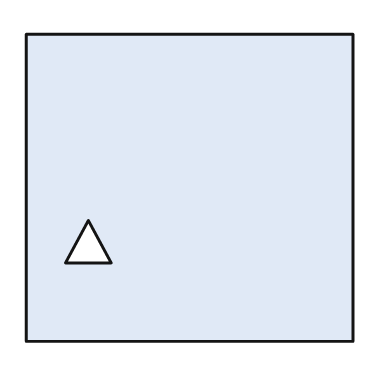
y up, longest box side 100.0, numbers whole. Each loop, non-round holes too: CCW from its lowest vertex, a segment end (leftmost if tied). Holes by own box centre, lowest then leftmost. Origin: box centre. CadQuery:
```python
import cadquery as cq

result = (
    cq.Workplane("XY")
    .moveTo(-50.0, -47.0)
    .lineTo(50.0, -47.0)
    .lineTo(50.0, 47.0)
    .lineTo(-50.0, 47.0)
    .close()
    .moveTo(-38.0, -23.0)
    .lineTo(-24.0, -23.0)
    .lineTo(-31.0, -10.0)
    .close()
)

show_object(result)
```